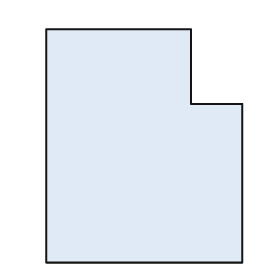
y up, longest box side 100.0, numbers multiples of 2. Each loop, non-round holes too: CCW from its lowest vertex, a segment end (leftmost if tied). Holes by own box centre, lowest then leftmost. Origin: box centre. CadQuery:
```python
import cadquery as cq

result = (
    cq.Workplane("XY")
    .moveTo(-42.0, -50.0)
    .lineTo(42.0, -50.0)
    .lineTo(42.0, 18.0)
    .lineTo(20.0, 18.0)
    .lineTo(20.0, 50.0)
    .lineTo(-42.0, 50.0)
    .close()
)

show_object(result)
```